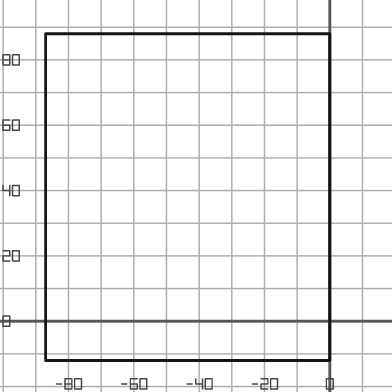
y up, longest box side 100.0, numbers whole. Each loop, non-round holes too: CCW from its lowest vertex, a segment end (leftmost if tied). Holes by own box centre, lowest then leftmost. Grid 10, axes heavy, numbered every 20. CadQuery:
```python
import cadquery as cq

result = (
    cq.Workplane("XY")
    .moveTo(-87.0, -12.0)
    .lineTo(0.0, -12.0)
    .lineTo(0.0, 88.0)
    .lineTo(-87.0, 88.0)
    .close()
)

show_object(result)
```